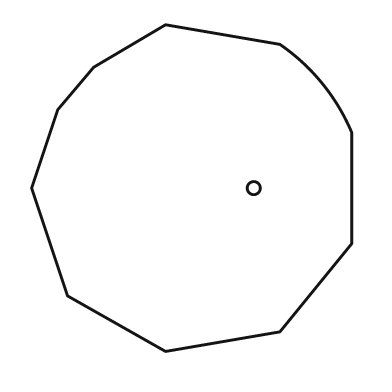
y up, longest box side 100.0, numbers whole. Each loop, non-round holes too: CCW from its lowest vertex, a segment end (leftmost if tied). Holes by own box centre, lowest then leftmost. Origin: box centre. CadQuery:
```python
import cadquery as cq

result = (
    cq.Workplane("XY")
    .moveTo(-8.0, -50.0)
    .lineTo(27.0, -44.0)
    .lineTo(49.0, -17.0)
    .lineTo(49.0, 17.0)
    .threePointArc((40.0, 32.0), (27.0, 44.0))
    .lineTo(-8.0, 50.0)
    .lineTo(-30.0, 37.0)
    .lineTo(-41.0, 24.0)
    .lineTo(-49.0, 0.0)
    .lineTo(-38.0, -33.0)
    .close()
    .moveTo(19.0, 0.0)
    .circle(2.0)
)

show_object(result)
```